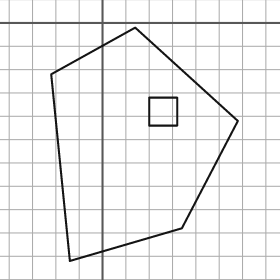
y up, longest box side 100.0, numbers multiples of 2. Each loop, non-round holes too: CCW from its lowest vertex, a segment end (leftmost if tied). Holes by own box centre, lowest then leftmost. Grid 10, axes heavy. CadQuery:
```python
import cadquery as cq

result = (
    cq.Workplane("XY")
    .moveTo(-14.0, -102.0)
    .lineTo(34.0, -88.0)
    .lineTo(58.0, -42.0)
    .lineTo(14.0, -2.0)
    .lineTo(-22.0, -22.0)
    .close()
    .moveTo(20.0, -44.0)
    .lineTo(32.0, -44.0)
    .lineTo(32.0, -32.0)
    .lineTo(20.0, -32.0)
    .close()
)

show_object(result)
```